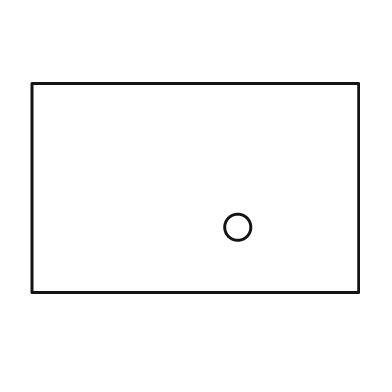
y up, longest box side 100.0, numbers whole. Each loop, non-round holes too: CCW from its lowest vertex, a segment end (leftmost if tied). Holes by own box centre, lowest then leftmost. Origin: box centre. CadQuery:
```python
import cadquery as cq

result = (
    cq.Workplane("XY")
    .moveTo(-50.0, -32.0)
    .lineTo(50.0, -32.0)
    .lineTo(50.0, 32.0)
    .lineTo(-50.0, 32.0)
    .close()
    .moveTo(13.0, -12.0)
    .circle(4.0)
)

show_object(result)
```